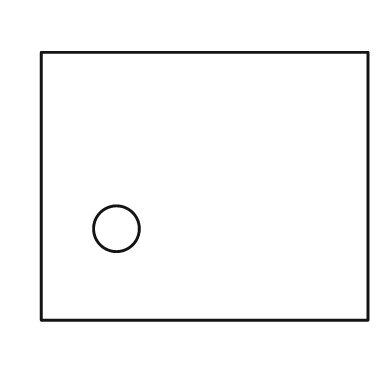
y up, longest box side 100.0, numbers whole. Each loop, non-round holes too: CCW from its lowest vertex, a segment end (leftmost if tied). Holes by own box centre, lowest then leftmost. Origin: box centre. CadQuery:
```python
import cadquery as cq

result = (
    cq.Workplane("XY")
    .moveTo(-50.0, -41.0)
    .lineTo(50.0, -41.0)
    .lineTo(50.0, 41.0)
    .lineTo(-50.0, 41.0)
    .close()
    .moveTo(-27.0, -13.0)
    .circle(7.0)
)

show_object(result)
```